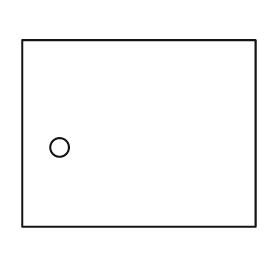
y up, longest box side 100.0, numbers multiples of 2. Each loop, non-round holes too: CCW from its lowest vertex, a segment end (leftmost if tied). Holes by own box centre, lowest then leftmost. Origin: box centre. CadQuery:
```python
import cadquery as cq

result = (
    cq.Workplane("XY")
    .moveTo(-50.0, -40.0)
    .lineTo(50.0, -40.0)
    .lineTo(50.0, 40.0)
    .lineTo(-50.0, 40.0)
    .close()
    .moveTo(-34.0, -6.0)
    .circle(4.0)
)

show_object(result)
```